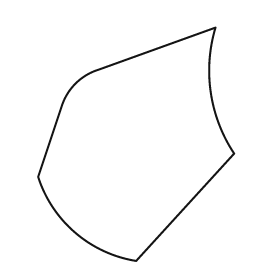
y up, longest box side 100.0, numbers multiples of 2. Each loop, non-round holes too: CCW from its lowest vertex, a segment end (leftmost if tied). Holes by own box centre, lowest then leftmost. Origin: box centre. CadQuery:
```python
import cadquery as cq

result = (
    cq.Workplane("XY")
    .moveTo(0.0, -50.0)
    .lineTo(42.0, -4.0)
    .threePointArc((32.0, 22.0), (34.0, 50.0))
    .lineTo(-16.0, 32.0)
    .threePointArc((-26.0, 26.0), (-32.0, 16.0))
    .lineTo(-42.0, -14.0)
    .threePointArc((-26.0, -38.0), (0.0, -50.0))
    .close()
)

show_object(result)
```